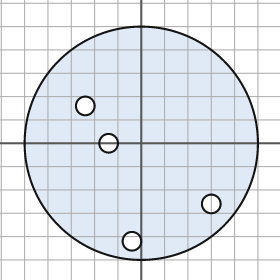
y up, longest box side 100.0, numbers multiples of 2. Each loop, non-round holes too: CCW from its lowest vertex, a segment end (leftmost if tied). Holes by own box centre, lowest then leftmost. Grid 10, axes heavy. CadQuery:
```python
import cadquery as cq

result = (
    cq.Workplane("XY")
    .moveTo(0.0, 0.0)
    .circle(50.0)
    .moveTo(-4.0, -42.0)
    .circle(4.0)
    .moveTo(30.0, -26.0)
    .circle(4.0)
    .moveTo(-14.0, 0.0)
    .circle(4.0)
    .moveTo(-24.0, 16.0)
    .circle(4.0)
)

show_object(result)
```